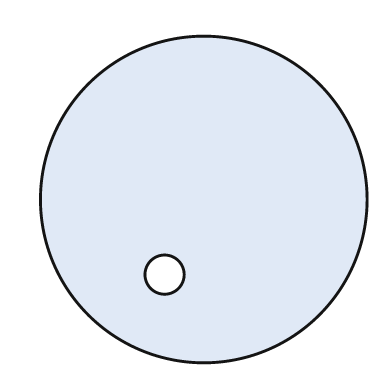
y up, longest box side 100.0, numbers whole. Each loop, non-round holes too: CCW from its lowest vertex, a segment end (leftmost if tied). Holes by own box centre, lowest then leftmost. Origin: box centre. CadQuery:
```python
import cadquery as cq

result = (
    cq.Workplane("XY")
    .moveTo(0.0, 0.0)
    .circle(50.0)
    .moveTo(-12.0, -23.0)
    .circle(6.0)
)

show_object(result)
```